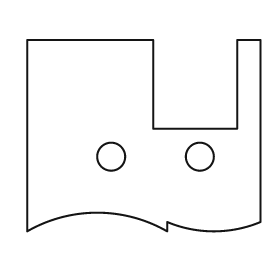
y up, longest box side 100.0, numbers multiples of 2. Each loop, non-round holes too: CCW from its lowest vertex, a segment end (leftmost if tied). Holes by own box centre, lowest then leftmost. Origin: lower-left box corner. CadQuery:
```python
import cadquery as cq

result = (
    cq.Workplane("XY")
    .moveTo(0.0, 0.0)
    .threePointArc((30.0, 8.0), (60.0, 0.0))
    .lineTo(60.0, 4.0)
    .threePointArc((80.0, 0.0), (100.0, 4.0))
    .lineTo(100.0, 82.0)
    .lineTo(90.0, 82.0)
    .lineTo(90.0, 44.0)
    .lineTo(54.0, 44.0)
    .lineTo(54.0, 82.0)
    .lineTo(0.0, 82.0)
    .close()
    .moveTo(36.0, 32.0)
    .circle(6.0)
    .moveTo(74.0, 32.0)
    .circle(6.0)
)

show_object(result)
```